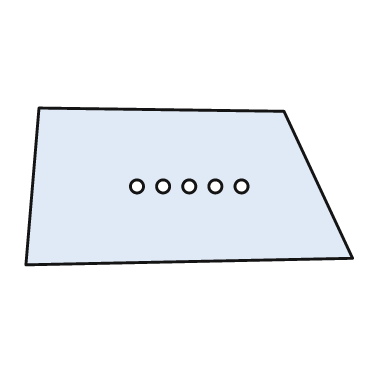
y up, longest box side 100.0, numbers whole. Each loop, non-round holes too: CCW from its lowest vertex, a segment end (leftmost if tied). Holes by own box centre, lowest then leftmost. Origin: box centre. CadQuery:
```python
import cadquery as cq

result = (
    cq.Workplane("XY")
    .moveTo(-50.0, -24.0)
    .lineTo(50.0, -22.0)
    .lineTo(29.0, 23.0)
    .lineTo(-46.0, 24.0)
    .close()
    .moveTo(-16.0, 0.0)
    .circle(2.0)
    .moveTo(-8.0, 0.0)
    .circle(2.0)
    .moveTo(0.0, 0.0)
    .circle(2.0)
    .moveTo(8.0, 0.0)
    .circle(2.0)
    .moveTo(16.0, 0.0)
    .circle(2.0)
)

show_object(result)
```